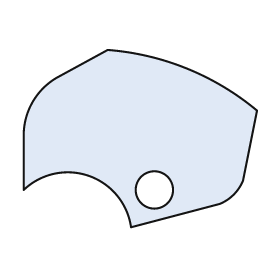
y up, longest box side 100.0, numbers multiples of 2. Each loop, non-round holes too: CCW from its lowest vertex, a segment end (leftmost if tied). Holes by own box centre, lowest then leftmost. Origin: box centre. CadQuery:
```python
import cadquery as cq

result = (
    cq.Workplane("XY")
    .moveTo(-4.0, -38.0)
    .lineTo(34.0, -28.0)
    .threePointArc((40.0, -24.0), (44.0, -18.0))
    .lineTo(50.0, 12.0)
    .threePointArc((20.0, 30.0), (-14.0, 38.0))
    .lineTo(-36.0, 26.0)
    .threePointArc((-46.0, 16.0), (-50.0, 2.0))
    .lineTo(-50.0, -22.0)
    .threePointArc((-22.0, -16.0), (-4.0, -38.0))
    .close()
    .moveTo(6.0, -22.0)
    .circle(8.0)
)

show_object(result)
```